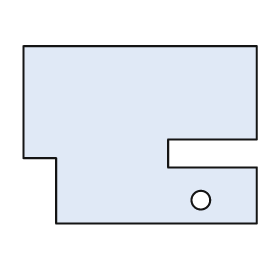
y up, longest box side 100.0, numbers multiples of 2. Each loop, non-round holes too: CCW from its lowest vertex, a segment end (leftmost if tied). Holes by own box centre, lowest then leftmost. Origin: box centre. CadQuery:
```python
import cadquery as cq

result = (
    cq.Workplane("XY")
    .moveTo(-36.0, -38.0)
    .lineTo(50.0, -38.0)
    .lineTo(50.0, -14.0)
    .lineTo(12.0, -14.0)
    .lineTo(12.0, -2.0)
    .lineTo(50.0, -2.0)
    .lineTo(50.0, 38.0)
    .lineTo(-50.0, 38.0)
    .lineTo(-50.0, -10.0)
    .lineTo(-36.0, -10.0)
    .close()
    .moveTo(26.0, -28.0)
    .circle(4.0)
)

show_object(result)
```